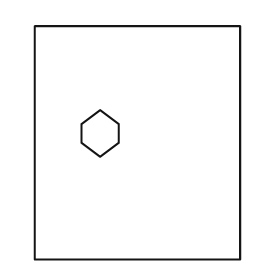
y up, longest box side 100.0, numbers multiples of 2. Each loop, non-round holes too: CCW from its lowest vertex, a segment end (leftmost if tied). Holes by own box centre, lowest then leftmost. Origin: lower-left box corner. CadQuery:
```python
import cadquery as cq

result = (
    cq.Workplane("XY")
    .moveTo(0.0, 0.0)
    .lineTo(88.0, 0.0)
    .lineTo(88.0, 100.0)
    .lineTo(0.0, 100.0)
    .close()
    .moveTo(28.0, 44.0)
    .lineTo(36.0, 50.0)
    .lineTo(36.0, 58.0)
    .lineTo(28.0, 64.0)
    .lineTo(20.0, 58.0)
    .lineTo(20.0, 50.0)
    .close()
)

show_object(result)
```